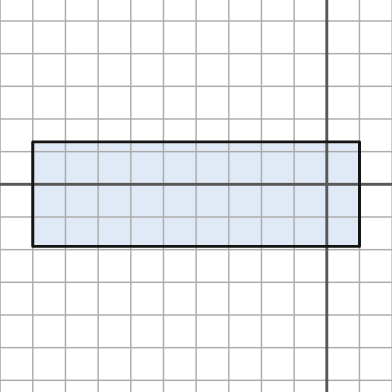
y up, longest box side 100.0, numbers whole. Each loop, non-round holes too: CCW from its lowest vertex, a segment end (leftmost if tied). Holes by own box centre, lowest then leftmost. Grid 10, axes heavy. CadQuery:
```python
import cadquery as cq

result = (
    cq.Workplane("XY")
    .moveTo(-90.0, -19.0)
    .lineTo(10.0, -19.0)
    .lineTo(10.0, 13.0)
    .lineTo(-90.0, 13.0)
    .close()
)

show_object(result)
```